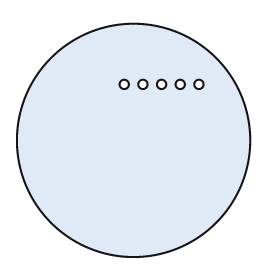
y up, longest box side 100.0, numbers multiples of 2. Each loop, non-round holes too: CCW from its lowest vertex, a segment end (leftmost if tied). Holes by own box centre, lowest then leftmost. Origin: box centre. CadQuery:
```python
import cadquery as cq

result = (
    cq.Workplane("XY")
    .moveTo(0.0, 0.0)
    .circle(50.0)
    .moveTo(-4.0, 24.0)
    .circle(2.0)
    .moveTo(4.0, 24.0)
    .circle(2.0)
    .moveTo(12.0, 24.0)
    .circle(2.0)
    .moveTo(20.0, 24.0)
    .circle(2.0)
    .moveTo(28.0, 24.0)
    .circle(2.0)
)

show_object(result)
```